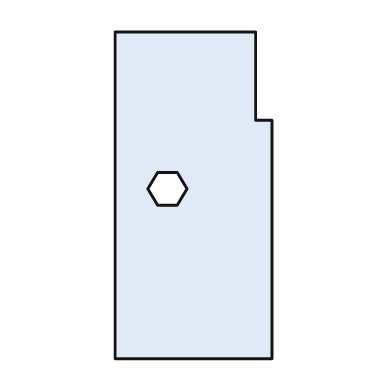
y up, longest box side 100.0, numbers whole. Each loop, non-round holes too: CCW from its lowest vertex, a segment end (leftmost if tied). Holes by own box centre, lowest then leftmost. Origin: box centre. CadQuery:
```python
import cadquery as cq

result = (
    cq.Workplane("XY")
    .moveTo(-24.0, -50.0)
    .lineTo(24.0, -50.0)
    .lineTo(24.0, 23.0)
    .lineTo(19.0, 23.0)
    .lineTo(19.0, 50.0)
    .lineTo(-24.0, 50.0)
    .close()
    .moveTo(-11.0, -3.0)
    .lineTo(-5.0, -3.0)
    .lineTo(-2.0, 2.0)
    .lineTo(-5.0, 7.0)
    .lineTo(-11.0, 7.0)
    .lineTo(-14.0, 2.0)
    .close()
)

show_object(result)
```